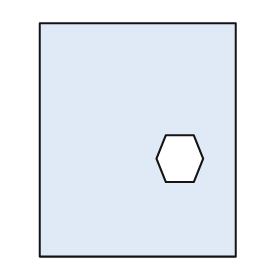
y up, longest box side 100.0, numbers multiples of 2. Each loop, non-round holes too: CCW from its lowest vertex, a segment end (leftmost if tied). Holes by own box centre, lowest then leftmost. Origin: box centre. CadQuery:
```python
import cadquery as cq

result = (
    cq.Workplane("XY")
    .moveTo(-42.0, -50.0)
    .lineTo(42.0, -50.0)
    .lineTo(42.0, 50.0)
    .lineTo(-42.0, 50.0)
    .close()
    .moveTo(12.0, -18.0)
    .lineTo(24.0, -18.0)
    .lineTo(28.0, -8.0)
    .lineTo(24.0, 2.0)
    .lineTo(12.0, 2.0)
    .lineTo(8.0, -8.0)
    .close()
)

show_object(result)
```